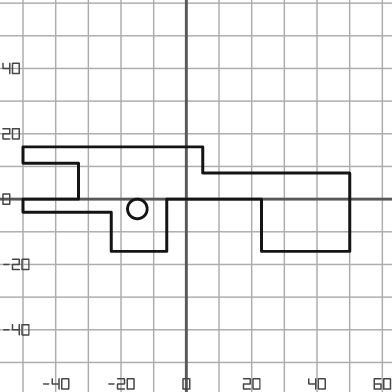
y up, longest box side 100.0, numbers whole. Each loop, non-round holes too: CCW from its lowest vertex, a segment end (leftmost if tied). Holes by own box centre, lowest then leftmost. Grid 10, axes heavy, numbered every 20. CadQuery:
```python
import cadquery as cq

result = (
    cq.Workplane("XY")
    .moveTo(-23.0, -16.0)
    .lineTo(-6.0, -16.0)
    .lineTo(-6.0, 0.0)
    .lineTo(23.0, 0.0)
    .lineTo(23.0, -16.0)
    .lineTo(50.0, -16.0)
    .lineTo(50.0, 8.0)
    .lineTo(5.0, 8.0)
    .lineTo(5.0, 16.0)
    .lineTo(-50.0, 16.0)
    .lineTo(-50.0, 11.0)
    .lineTo(-33.0, 11.0)
    .lineTo(-33.0, 0.0)
    .lineTo(-50.0, 0.0)
    .lineTo(-50.0, -4.0)
    .lineTo(-23.0, -4.0)
    .close()
    .moveTo(-15.0, -3.0)
    .circle(3.0)
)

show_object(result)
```